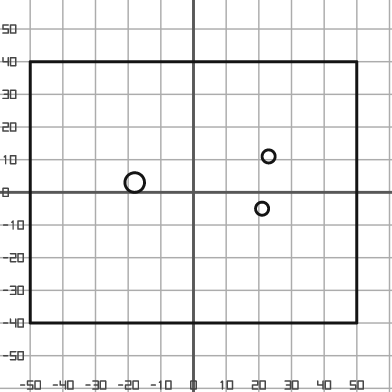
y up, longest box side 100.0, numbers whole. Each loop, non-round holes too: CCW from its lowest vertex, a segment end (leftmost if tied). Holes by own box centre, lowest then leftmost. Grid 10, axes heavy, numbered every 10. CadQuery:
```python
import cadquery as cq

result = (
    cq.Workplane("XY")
    .moveTo(-50.0, -40.0)
    .lineTo(50.0, -40.0)
    .lineTo(50.0, 40.0)
    .lineTo(-50.0, 40.0)
    .close()
    .moveTo(21.0, -5.0)
    .circle(2.0)
    .moveTo(-18.0, 3.0)
    .circle(3.0)
    .moveTo(23.0, 11.0)
    .circle(2.0)
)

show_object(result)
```